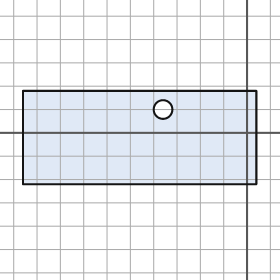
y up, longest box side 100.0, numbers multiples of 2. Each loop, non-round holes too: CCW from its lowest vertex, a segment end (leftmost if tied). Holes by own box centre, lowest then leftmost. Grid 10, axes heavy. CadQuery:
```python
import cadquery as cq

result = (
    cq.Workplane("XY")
    .moveTo(-96.0, -22.0)
    .lineTo(4.0, -22.0)
    .lineTo(4.0, 18.0)
    .lineTo(-96.0, 18.0)
    .close()
    .moveTo(-36.0, 10.0)
    .circle(4.0)
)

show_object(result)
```